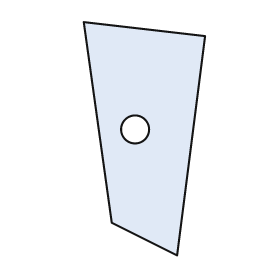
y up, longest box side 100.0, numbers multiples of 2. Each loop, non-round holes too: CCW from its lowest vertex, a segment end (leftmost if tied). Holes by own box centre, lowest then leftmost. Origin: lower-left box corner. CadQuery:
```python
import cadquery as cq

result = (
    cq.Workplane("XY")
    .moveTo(40.0, 0.0)
    .lineTo(52.0, 94.0)
    .lineTo(0.0, 100.0)
    .lineTo(12.0, 14.0)
    .close()
    .moveTo(22.0, 54.0)
    .circle(6.0)
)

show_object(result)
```